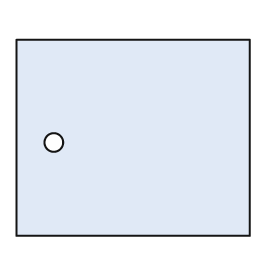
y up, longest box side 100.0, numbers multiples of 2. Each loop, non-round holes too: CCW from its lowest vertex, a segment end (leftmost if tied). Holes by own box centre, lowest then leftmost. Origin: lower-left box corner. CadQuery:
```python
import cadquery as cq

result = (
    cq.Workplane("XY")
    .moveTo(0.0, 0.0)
    .lineTo(100.0, 0.0)
    .lineTo(100.0, 84.0)
    .lineTo(0.0, 84.0)
    .close()
    .moveTo(16.0, 40.0)
    .circle(4.0)
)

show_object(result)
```